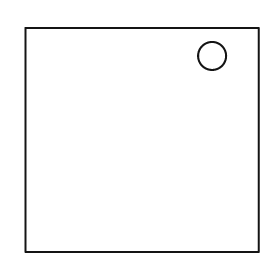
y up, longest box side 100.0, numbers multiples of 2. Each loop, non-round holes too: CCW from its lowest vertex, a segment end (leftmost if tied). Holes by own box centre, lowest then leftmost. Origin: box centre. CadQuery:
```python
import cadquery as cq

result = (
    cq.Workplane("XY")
    .moveTo(-50.0, -48.0)
    .lineTo(50.0, -48.0)
    .lineTo(50.0, 48.0)
    .lineTo(-50.0, 48.0)
    .close()
    .moveTo(30.0, 36.0)
    .circle(6.0)
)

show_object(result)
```